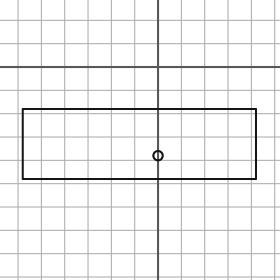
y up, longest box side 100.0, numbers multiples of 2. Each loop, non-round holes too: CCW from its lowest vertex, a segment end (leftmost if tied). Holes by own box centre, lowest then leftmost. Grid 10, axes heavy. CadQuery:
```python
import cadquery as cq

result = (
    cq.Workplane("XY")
    .moveTo(-58.0, -48.0)
    .lineTo(42.0, -48.0)
    .lineTo(42.0, -18.0)
    .lineTo(-58.0, -18.0)
    .close()
    .moveTo(0.0, -38.0)
    .circle(2.0)
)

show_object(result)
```